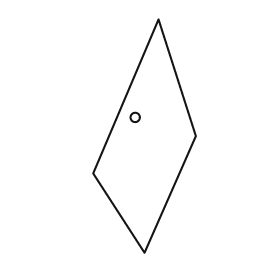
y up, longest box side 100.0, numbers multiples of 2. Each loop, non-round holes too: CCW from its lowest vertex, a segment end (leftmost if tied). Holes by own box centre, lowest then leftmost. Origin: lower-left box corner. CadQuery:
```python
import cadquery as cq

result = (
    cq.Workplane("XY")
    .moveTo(22.0, 0.0)
    .lineTo(44.0, 50.0)
    .lineTo(28.0, 100.0)
    .lineTo(0.0, 34.0)
    .close()
    .moveTo(18.0, 58.0)
    .circle(2.0)
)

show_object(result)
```